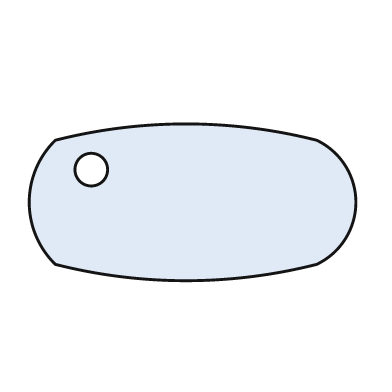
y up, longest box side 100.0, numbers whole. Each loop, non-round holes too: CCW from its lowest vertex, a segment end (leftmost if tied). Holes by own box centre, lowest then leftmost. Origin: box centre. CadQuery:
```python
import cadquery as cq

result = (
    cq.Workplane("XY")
    .moveTo(-42.0, -19.0)
    .threePointArc((-2.0, -24.0), (38.0, -19.0))
    .threePointArc((50.0, 0.0), (38.0, 19.0))
    .threePointArc((-2.0, 24.0), (-42.0, 19.0))
    .threePointArc((-50.0, 0.0), (-42.0, -19.0))
    .close()
    .moveTo(-31.0, 10.0)
    .circle(5.0)
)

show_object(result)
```